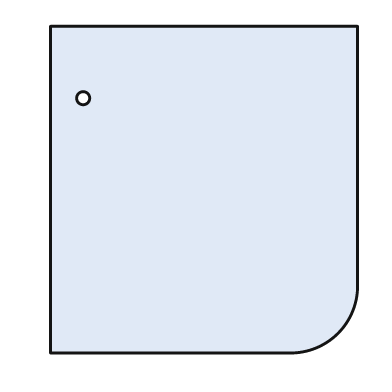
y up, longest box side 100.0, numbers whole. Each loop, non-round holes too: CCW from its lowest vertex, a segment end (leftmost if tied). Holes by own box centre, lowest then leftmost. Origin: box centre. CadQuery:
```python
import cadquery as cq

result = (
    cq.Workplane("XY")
    .moveTo(-47.0, -50.0)
    .lineTo(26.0, -50.0)
    .threePointArc((41.0, -44.0), (47.0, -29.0))
    .lineTo(47.0, 50.0)
    .lineTo(-47.0, 50.0)
    .close()
    .moveTo(-37.0, 28.0)
    .circle(2.0)
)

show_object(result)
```